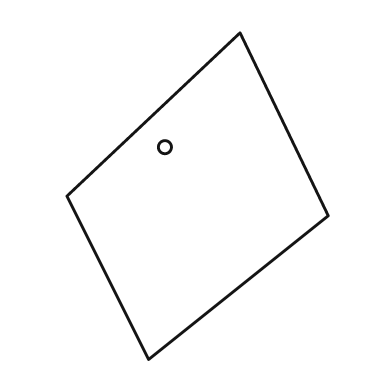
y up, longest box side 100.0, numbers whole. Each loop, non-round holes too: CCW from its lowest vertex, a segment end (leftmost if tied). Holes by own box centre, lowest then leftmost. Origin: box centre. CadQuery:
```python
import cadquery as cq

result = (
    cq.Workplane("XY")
    .moveTo(-15.0, -50.0)
    .lineTo(40.0, -6.0)
    .lineTo(13.0, 50.0)
    .lineTo(-40.0, 0.0)
    .close()
    .moveTo(-10.0, 15.0)
    .circle(2.0)
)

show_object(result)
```